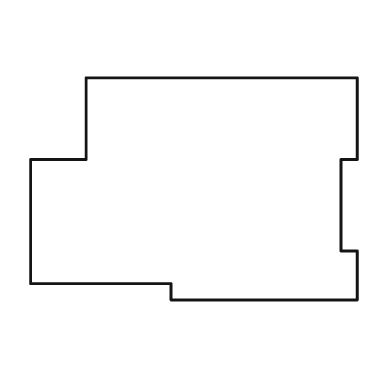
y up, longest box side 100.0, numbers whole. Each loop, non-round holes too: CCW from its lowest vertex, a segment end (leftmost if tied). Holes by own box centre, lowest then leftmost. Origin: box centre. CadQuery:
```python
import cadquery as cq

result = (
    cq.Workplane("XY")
    .moveTo(-7.0, -34.0)
    .lineTo(50.0, -34.0)
    .lineTo(50.0, -19.0)
    .lineTo(45.0, -19.0)
    .lineTo(45.0, 9.0)
    .lineTo(50.0, 9.0)
    .lineTo(50.0, 34.0)
    .lineTo(-33.0, 34.0)
    .lineTo(-33.0, 9.0)
    .lineTo(-50.0, 9.0)
    .lineTo(-50.0, -29.0)
    .lineTo(-7.0, -29.0)
    .close()
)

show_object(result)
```